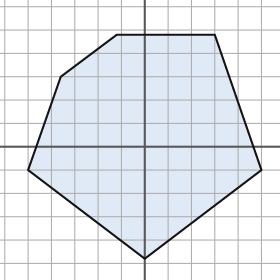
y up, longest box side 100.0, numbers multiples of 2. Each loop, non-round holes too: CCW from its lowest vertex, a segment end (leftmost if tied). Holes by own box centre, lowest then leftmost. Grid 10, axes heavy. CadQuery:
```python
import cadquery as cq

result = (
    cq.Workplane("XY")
    .moveTo(0.0, -48.0)
    .lineTo(50.0, -10.0)
    .lineTo(30.0, 48.0)
    .lineTo(-12.0, 48.0)
    .lineTo(-36.0, 30.0)
    .lineTo(-50.0, -10.0)
    .close()
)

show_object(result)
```